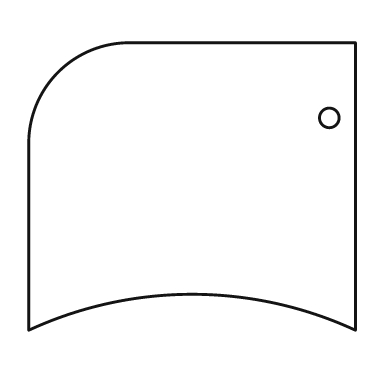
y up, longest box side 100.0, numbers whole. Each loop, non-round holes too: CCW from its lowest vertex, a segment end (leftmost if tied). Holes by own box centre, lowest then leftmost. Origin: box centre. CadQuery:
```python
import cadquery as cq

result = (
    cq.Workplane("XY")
    .moveTo(-50.0, -44.0)
    .threePointArc((0.0, -33.0), (50.0, -44.0))
    .lineTo(50.0, 44.0)
    .lineTo(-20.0, 44.0)
    .threePointArc((-41.0, 35.0), (-50.0, 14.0))
    .close()
    .moveTo(42.0, 21.0)
    .circle(3.0)
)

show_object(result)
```